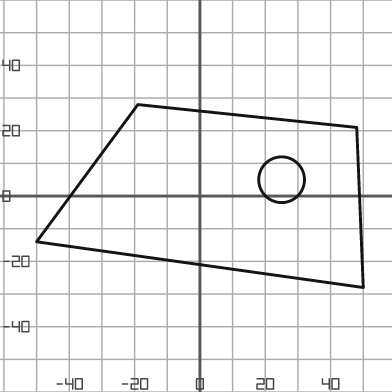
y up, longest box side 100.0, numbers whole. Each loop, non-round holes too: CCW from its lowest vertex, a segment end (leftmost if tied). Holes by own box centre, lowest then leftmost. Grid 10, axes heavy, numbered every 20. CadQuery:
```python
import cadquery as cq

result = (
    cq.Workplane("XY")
    .moveTo(50.0, -28.0)
    .lineTo(48.0, 21.0)
    .lineTo(-19.0, 28.0)
    .lineTo(-50.0, -14.0)
    .close()
    .moveTo(25.0, 5.0)
    .circle(7.0)
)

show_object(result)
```